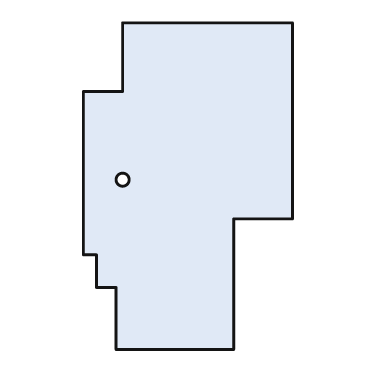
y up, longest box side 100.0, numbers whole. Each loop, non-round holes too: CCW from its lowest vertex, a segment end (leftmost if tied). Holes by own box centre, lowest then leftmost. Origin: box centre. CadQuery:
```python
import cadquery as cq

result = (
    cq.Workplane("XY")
    .moveTo(-22.0, -50.0)
    .lineTo(14.0, -50.0)
    .lineTo(14.0, -10.0)
    .lineTo(32.0, -10.0)
    .lineTo(32.0, 50.0)
    .lineTo(-20.0, 50.0)
    .lineTo(-20.0, 29.0)
    .lineTo(-32.0, 29.0)
    .lineTo(-32.0, -21.0)
    .lineTo(-28.0, -21.0)
    .lineTo(-28.0, -31.0)
    .lineTo(-22.0, -31.0)
    .close()
    .moveTo(-20.0, 2.0)
    .circle(2.0)
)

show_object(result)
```